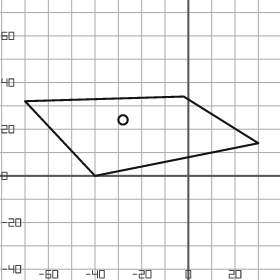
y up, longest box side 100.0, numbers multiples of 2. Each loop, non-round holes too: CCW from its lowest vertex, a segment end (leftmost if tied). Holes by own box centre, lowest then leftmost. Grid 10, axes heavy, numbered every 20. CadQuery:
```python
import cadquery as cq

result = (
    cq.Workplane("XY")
    .moveTo(-40.0, 0.0)
    .lineTo(30.0, 14.0)
    .lineTo(-2.0, 34.0)
    .lineTo(-70.0, 32.0)
    .close()
    .moveTo(-28.0, 24.0)
    .circle(2.0)
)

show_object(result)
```